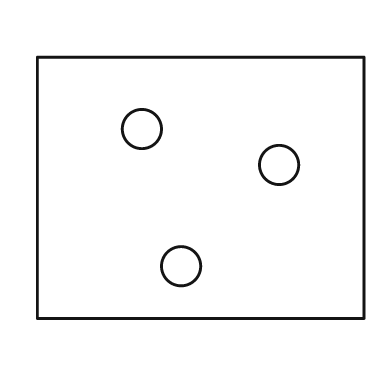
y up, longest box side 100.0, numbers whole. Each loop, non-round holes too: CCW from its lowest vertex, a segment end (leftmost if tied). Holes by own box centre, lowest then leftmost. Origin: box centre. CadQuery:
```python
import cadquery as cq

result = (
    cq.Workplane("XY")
    .moveTo(-50.0, -40.0)
    .lineTo(50.0, -40.0)
    .lineTo(50.0, 40.0)
    .lineTo(-50.0, 40.0)
    .close()
    .moveTo(-6.0, -24.0)
    .circle(6.0)
    .moveTo(24.0, 7.0)
    .circle(6.0)
    .moveTo(-18.0, 18.0)
    .circle(6.0)
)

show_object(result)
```